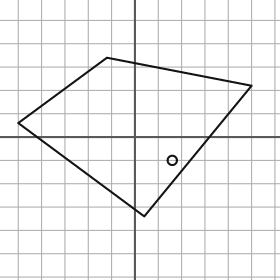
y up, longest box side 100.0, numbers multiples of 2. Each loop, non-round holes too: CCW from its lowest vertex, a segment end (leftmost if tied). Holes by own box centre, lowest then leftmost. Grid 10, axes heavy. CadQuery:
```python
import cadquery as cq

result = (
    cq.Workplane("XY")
    .moveTo(4.0, -34.0)
    .lineTo(50.0, 22.0)
    .lineTo(-12.0, 34.0)
    .lineTo(-50.0, 6.0)
    .close()
    .moveTo(16.0, -10.0)
    .circle(2.0)
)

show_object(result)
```